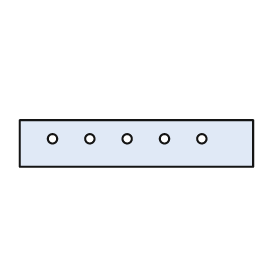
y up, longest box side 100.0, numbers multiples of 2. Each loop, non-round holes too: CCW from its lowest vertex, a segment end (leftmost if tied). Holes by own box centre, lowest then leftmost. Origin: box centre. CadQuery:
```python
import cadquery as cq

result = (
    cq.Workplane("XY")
    .moveTo(-50.0, -10.0)
    .lineTo(50.0, -10.0)
    .lineTo(50.0, 10.0)
    .lineTo(-50.0, 10.0)
    .close()
    .moveTo(-36.0, 2.0)
    .circle(2.0)
    .moveTo(-20.0, 2.0)
    .circle(2.0)
    .moveTo(-4.0, 2.0)
    .circle(2.0)
    .moveTo(12.0, 2.0)
    .circle(2.0)
    .moveTo(28.0, 2.0)
    .circle(2.0)
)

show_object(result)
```